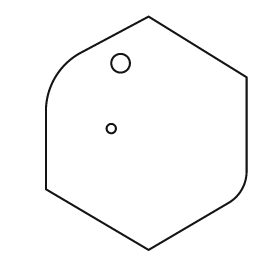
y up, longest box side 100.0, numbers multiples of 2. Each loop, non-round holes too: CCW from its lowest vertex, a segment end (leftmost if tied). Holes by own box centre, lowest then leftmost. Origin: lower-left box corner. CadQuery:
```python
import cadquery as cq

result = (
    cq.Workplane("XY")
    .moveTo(44.0, 0.0)
    .lineTo(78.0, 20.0)
    .threePointArc((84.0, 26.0), (86.0, 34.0))
    .lineTo(86.0, 74.0)
    .lineTo(44.0, 100.0)
    .lineTo(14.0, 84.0)
    .threePointArc((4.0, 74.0), (0.0, 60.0))
    .lineTo(0.0, 26.0)
    .close()
    .moveTo(28.0, 52.0)
    .circle(2.0)
    .moveTo(32.0, 80.0)
    .circle(4.0)
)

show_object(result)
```